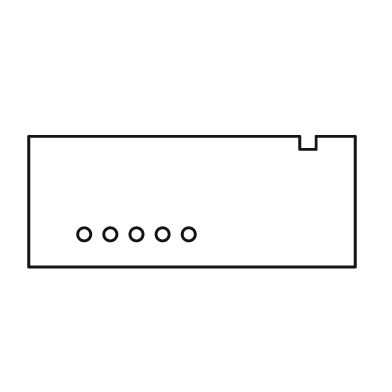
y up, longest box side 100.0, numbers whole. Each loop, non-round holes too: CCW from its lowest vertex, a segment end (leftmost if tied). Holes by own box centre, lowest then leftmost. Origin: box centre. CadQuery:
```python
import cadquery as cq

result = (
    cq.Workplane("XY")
    .moveTo(-50.0, -20.0)
    .lineTo(50.0, -20.0)
    .lineTo(50.0, 20.0)
    .lineTo(38.0, 20.0)
    .lineTo(38.0, 16.0)
    .lineTo(33.0, 16.0)
    .lineTo(33.0, 20.0)
    .lineTo(-50.0, 20.0)
    .close()
    .moveTo(-33.0, -10.0)
    .circle(2.0)
    .moveTo(-25.0, -10.0)
    .circle(2.0)
    .moveTo(-17.0, -10.0)
    .circle(2.0)
    .moveTo(-9.0, -10.0)
    .circle(2.0)
    .moveTo(-1.0, -10.0)
    .circle(2.0)
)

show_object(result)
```